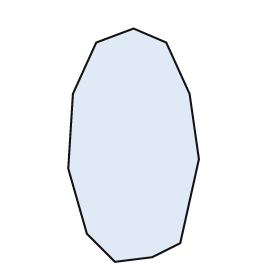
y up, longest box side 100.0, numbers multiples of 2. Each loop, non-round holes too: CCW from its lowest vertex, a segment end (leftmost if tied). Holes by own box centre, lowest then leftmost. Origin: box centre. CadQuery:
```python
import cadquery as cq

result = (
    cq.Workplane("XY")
    .moveTo(-8.0, -50.0)
    .lineTo(8.0, -48.0)
    .lineTo(20.0, -42.0)
    .lineTo(28.0, -6.0)
    .lineTo(24.0, 22.0)
    .lineTo(14.0, 44.0)
    .lineTo(0.0, 50.0)
    .lineTo(-16.0, 44.0)
    .lineTo(-26.0, 22.0)
    .lineTo(-28.0, -10.0)
    .lineTo(-20.0, -38.0)
    .close()
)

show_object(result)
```